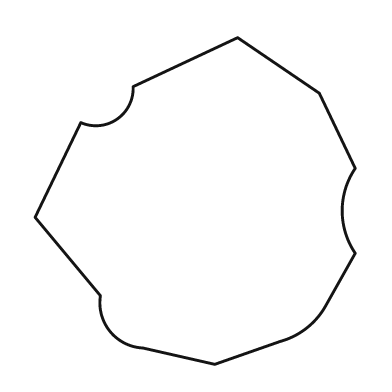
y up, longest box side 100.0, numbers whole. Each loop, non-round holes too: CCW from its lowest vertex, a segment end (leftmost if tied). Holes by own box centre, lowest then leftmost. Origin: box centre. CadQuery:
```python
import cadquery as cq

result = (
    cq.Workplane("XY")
    .moveTo(6.0, -50.0)
    .lineTo(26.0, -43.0)
    .threePointArc((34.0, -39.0), (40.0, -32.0))
    .lineTo(49.0, -16.0)
    .threePointArc((45.0, -3.0), (49.0, 10.0))
    .lineTo(38.0, 33.0)
    .lineTo(13.0, 50.0)
    .lineTo(-19.0, 35.0)
    .threePointArc((-24.0, 25.0), (-35.0, 24.0))
    .lineTo(-49.0, -5.0)
    .lineTo(-29.0, -29.0)
    .threePointArc((-26.0, -40.0), (-16.0, -45.0))
    .close()
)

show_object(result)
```